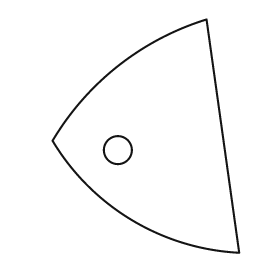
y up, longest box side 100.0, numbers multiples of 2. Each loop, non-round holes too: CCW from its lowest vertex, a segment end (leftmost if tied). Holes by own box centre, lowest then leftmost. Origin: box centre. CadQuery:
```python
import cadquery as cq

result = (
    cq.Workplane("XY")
    .moveTo(40.0, -50.0)
    .lineTo(26.0, 50.0)
    .threePointArc((-12.0, 30.0), (-40.0, -2.0))
    .threePointArc((-6.0, -36.0), (40.0, -50.0))
    .close()
    .moveTo(-12.0, -6.0)
    .circle(6.0)
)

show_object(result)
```